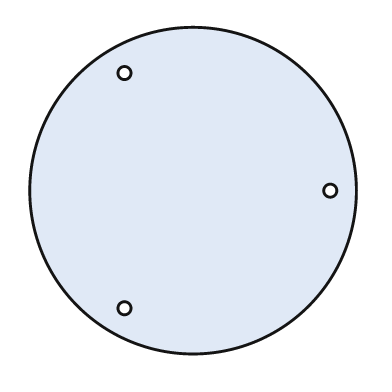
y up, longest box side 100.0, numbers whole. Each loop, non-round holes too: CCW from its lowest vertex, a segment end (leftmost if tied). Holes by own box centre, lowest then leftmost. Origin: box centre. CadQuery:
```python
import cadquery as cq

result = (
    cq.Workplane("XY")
    .moveTo(0.0, 0.0)
    .circle(50.0)
    .moveTo(-21.0, -36.0)
    .circle(2.0)
    .moveTo(42.0, 0.0)
    .circle(2.0)
    .moveTo(-21.0, 36.0)
    .circle(2.0)
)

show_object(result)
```